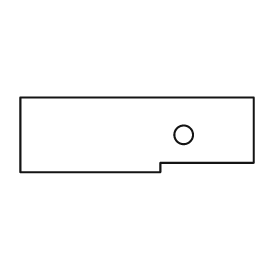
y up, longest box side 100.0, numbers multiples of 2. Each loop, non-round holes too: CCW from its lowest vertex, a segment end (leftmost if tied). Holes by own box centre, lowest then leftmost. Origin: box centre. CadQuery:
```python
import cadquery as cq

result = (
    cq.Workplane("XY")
    .moveTo(-50.0, -16.0)
    .lineTo(10.0, -16.0)
    .lineTo(10.0, -12.0)
    .lineTo(50.0, -12.0)
    .lineTo(50.0, 16.0)
    .lineTo(-50.0, 16.0)
    .close()
    .moveTo(20.0, 0.0)
    .circle(4.0)
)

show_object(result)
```